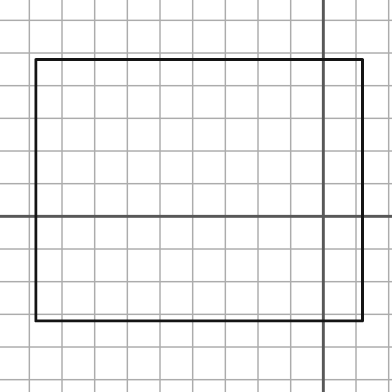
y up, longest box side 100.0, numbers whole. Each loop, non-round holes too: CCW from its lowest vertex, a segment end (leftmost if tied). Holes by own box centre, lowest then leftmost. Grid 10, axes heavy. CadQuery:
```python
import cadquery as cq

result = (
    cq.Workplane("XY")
    .moveTo(-88.0, -32.0)
    .lineTo(12.0, -32.0)
    .lineTo(12.0, 48.0)
    .lineTo(-88.0, 48.0)
    .close()
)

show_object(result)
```